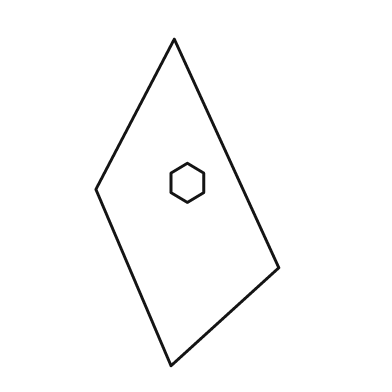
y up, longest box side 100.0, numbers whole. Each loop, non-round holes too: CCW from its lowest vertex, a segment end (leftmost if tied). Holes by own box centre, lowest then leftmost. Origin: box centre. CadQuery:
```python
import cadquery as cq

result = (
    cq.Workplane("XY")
    .moveTo(-5.0, -50.0)
    .lineTo(28.0, -20.0)
    .lineTo(-4.0, 50.0)
    .lineTo(-28.0, 4.0)
    .close()
    .moveTo(0.0, 0.0)
    .lineTo(5.0, 3.0)
    .lineTo(5.0, 9.0)
    .lineTo(0.0, 12.0)
    .lineTo(-5.0, 9.0)
    .lineTo(-5.0, 3.0)
    .close()
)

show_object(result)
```